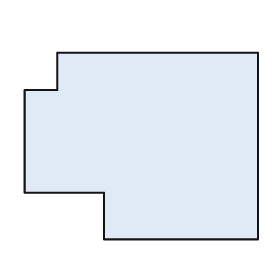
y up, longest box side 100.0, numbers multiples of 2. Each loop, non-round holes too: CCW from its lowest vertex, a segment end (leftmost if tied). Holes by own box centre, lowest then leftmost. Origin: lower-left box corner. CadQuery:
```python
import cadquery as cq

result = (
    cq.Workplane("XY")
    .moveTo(34.0, 0.0)
    .lineTo(100.0, 0.0)
    .lineTo(100.0, 80.0)
    .lineTo(14.0, 80.0)
    .lineTo(14.0, 64.0)
    .lineTo(0.0, 64.0)
    .lineTo(0.0, 20.0)
    .lineTo(34.0, 20.0)
    .close()
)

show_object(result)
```